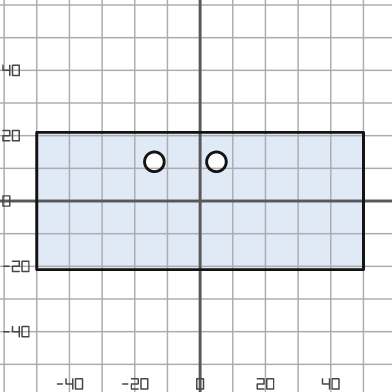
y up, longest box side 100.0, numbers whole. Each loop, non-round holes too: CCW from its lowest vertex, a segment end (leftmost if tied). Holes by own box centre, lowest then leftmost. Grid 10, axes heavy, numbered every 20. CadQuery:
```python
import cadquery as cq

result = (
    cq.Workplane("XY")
    .moveTo(-50.0, -21.0)
    .lineTo(50.0, -21.0)
    .lineTo(50.0, 21.0)
    .lineTo(-50.0, 21.0)
    .close()
    .moveTo(-14.0, 12.0)
    .circle(3.0)
    .moveTo(5.0, 12.0)
    .circle(3.0)
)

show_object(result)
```